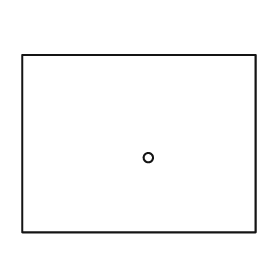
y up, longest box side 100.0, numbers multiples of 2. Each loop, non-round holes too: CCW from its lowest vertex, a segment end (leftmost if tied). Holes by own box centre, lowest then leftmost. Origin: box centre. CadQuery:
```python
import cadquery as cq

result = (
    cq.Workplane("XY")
    .moveTo(-50.0, -38.0)
    .lineTo(50.0, -38.0)
    .lineTo(50.0, 38.0)
    .lineTo(-50.0, 38.0)
    .close()
    .moveTo(4.0, -6.0)
    .circle(2.0)
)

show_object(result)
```